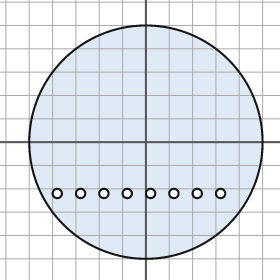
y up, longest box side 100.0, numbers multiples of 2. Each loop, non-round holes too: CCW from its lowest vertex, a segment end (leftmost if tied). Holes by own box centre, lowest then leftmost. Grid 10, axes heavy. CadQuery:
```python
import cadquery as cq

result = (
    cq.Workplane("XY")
    .moveTo(0.0, 0.0)
    .circle(50.0)
    .moveTo(-38.0, -22.0)
    .circle(2.0)
    .moveTo(-28.0, -22.0)
    .circle(2.0)
    .moveTo(-18.0, -22.0)
    .circle(2.0)
    .moveTo(-8.0, -22.0)
    .circle(2.0)
    .moveTo(2.0, -22.0)
    .circle(2.0)
    .moveTo(12.0, -22.0)
    .circle(2.0)
    .moveTo(22.0, -22.0)
    .circle(2.0)
    .moveTo(32.0, -22.0)
    .circle(2.0)
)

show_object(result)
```